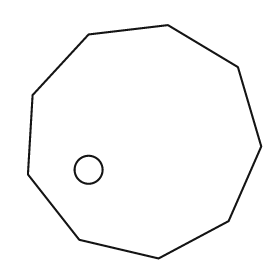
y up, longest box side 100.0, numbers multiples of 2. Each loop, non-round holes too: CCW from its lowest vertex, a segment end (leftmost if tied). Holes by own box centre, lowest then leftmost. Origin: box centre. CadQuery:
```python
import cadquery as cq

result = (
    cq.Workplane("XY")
    .moveTo(6.0, -50.0)
    .lineTo(36.0, -34.0)
    .lineTo(50.0, -2.0)
    .lineTo(40.0, 32.0)
    .lineTo(10.0, 50.0)
    .lineTo(-24.0, 46.0)
    .lineTo(-48.0, 20.0)
    .lineTo(-50.0, -14.0)
    .lineTo(-28.0, -42.0)
    .close()
    .moveTo(-24.0, -12.0)
    .circle(6.0)
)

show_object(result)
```